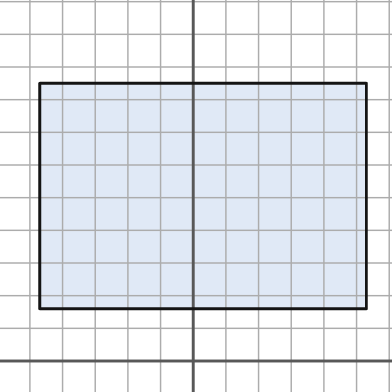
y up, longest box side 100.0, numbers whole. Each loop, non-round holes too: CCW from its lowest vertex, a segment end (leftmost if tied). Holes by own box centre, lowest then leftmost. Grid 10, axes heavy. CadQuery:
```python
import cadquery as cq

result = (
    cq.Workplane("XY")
    .moveTo(-47.0, 16.0)
    .lineTo(53.0, 16.0)
    .lineTo(53.0, 85.0)
    .lineTo(-47.0, 85.0)
    .close()
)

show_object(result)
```